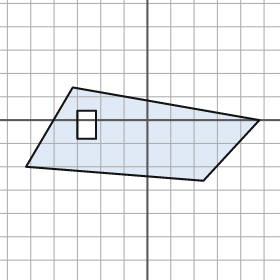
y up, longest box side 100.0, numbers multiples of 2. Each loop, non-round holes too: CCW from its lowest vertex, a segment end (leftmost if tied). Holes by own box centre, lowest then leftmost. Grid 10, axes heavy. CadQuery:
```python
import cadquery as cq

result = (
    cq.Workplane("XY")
    .moveTo(24.0, -26.0)
    .lineTo(48.0, 0.0)
    .lineTo(-32.0, 14.0)
    .lineTo(-52.0, -20.0)
    .close()
    .moveTo(-30.0, -8.0)
    .lineTo(-22.0, -8.0)
    .lineTo(-22.0, 4.0)
    .lineTo(-30.0, 4.0)
    .close()
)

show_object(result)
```